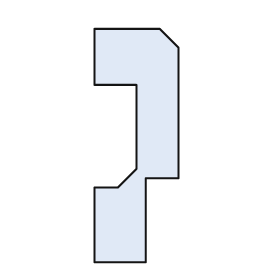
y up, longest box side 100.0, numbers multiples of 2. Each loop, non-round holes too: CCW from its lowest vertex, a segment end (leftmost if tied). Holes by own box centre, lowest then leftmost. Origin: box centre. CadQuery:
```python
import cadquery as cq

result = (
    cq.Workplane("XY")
    .moveTo(-18.0, -50.0)
    .lineTo(4.0, -50.0)
    .lineTo(4.0, -14.0)
    .lineTo(18.0, -14.0)
    .lineTo(18.0, 42.0)
    .lineTo(10.0, 50.0)
    .lineTo(-18.0, 50.0)
    .lineTo(-18.0, 26.0)
    .lineTo(0.0, 26.0)
    .lineTo(0.0, -10.0)
    .lineTo(-8.0, -18.0)
    .lineTo(-18.0, -18.0)
    .close()
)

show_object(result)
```